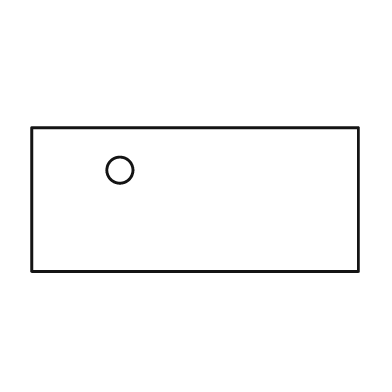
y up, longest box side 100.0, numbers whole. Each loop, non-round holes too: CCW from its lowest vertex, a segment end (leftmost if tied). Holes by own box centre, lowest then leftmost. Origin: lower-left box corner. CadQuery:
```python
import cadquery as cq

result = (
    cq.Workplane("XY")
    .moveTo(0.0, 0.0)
    .lineTo(100.0, 0.0)
    .lineTo(100.0, 44.0)
    .lineTo(0.0, 44.0)
    .close()
    .moveTo(27.0, 31.0)
    .circle(4.0)
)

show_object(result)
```